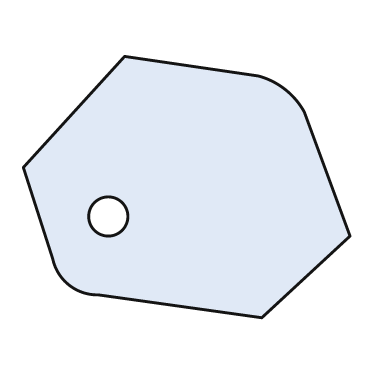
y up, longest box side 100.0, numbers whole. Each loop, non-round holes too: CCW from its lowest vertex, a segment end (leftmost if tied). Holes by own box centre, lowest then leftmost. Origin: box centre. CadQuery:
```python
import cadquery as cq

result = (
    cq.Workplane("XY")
    .moveTo(23.0, -40.0)
    .lineTo(50.0, -15.0)
    .lineTo(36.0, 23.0)
    .threePointArc((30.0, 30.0), (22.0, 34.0))
    .lineTo(-19.0, 40.0)
    .lineTo(-50.0, 6.0)
    .lineTo(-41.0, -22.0)
    .threePointArc((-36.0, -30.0), (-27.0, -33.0))
    .close()
    .moveTo(-24.0, -9.0)
    .circle(6.0)
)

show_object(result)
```